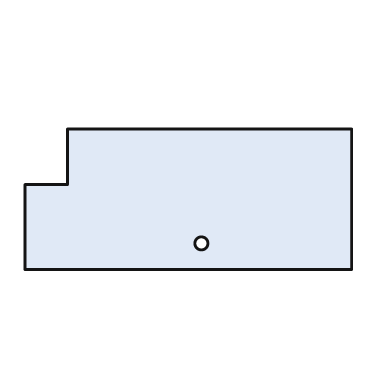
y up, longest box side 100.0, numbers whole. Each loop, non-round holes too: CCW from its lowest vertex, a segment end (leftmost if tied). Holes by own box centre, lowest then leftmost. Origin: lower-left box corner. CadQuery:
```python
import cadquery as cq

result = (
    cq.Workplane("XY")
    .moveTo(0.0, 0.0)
    .lineTo(100.0, 0.0)
    .lineTo(100.0, 43.0)
    .lineTo(13.0, 43.0)
    .lineTo(13.0, 26.0)
    .lineTo(0.0, 26.0)
    .close()
    .moveTo(54.0, 8.0)
    .circle(2.0)
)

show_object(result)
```